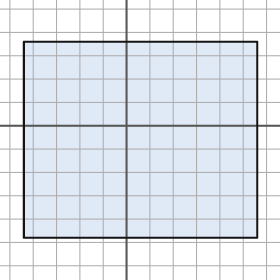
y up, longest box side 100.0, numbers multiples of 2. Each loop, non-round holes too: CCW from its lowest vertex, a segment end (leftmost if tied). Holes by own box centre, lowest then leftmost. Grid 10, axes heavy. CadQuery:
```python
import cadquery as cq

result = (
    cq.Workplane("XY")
    .moveTo(-44.0, -48.0)
    .lineTo(56.0, -48.0)
    .lineTo(56.0, 36.0)
    .lineTo(-44.0, 36.0)
    .close()
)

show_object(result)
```